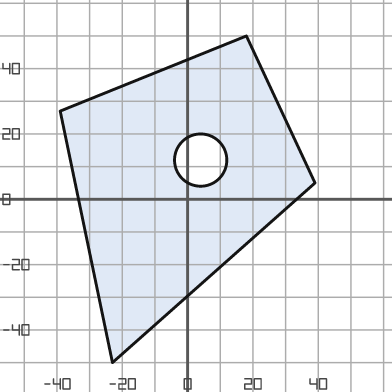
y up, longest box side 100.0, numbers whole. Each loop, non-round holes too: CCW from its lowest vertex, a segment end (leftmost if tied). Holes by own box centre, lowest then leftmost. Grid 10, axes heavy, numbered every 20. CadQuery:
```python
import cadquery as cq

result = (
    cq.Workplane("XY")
    .moveTo(-23.0, -50.0)
    .lineTo(39.0, 5.0)
    .lineTo(18.0, 50.0)
    .lineTo(-39.0, 27.0)
    .close()
    .moveTo(4.0, 12.0)
    .circle(8.0)
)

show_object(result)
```